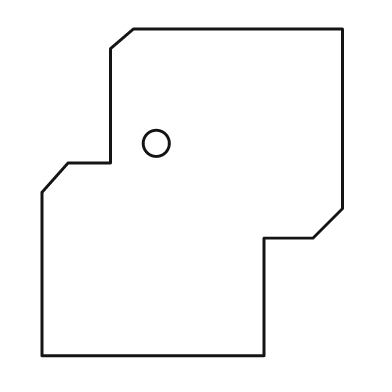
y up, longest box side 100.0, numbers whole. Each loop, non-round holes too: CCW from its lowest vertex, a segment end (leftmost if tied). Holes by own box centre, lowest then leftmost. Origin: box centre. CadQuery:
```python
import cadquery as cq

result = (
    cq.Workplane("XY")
    .moveTo(-46.0, -50.0)
    .lineTo(22.0, -50.0)
    .lineTo(22.0, -14.0)
    .lineTo(37.0, -14.0)
    .lineTo(46.0, -5.0)
    .lineTo(46.0, 50.0)
    .lineTo(-18.0, 50.0)
    .lineTo(-25.0, 44.0)
    .lineTo(-25.0, 9.0)
    .lineTo(-38.0, 9.0)
    .lineTo(-46.0, 0.0)
    .close()
    .moveTo(-11.0, 15.0)
    .circle(4.0)
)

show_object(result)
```